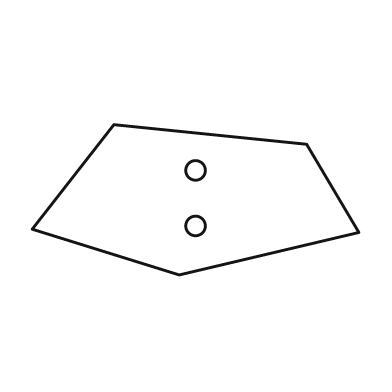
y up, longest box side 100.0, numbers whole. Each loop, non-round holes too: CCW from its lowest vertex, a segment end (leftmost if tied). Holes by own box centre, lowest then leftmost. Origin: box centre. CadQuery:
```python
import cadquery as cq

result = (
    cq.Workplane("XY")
    .moveTo(-5.0, -23.0)
    .lineTo(50.0, -10.0)
    .lineTo(34.0, 17.0)
    .lineTo(-25.0, 23.0)
    .lineTo(-50.0, -9.0)
    .close()
    .moveTo(0.0, -8.0)
    .circle(3.0)
    .moveTo(0.0, 9.0)
    .circle(3.0)
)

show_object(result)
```